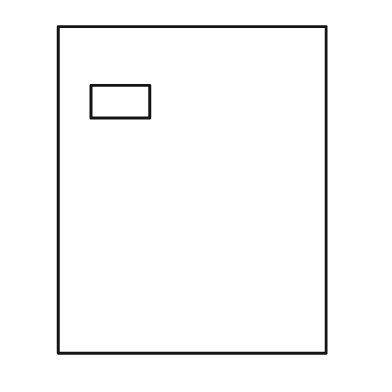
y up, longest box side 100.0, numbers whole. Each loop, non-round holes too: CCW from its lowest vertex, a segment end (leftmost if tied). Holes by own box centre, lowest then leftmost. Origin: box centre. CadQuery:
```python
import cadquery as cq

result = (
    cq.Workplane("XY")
    .moveTo(-41.0, -50.0)
    .lineTo(41.0, -50.0)
    .lineTo(41.0, 50.0)
    .lineTo(-41.0, 50.0)
    .close()
    .moveTo(-31.0, 22.0)
    .lineTo(-13.0, 22.0)
    .lineTo(-13.0, 32.0)
    .lineTo(-31.0, 32.0)
    .close()
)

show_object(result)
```